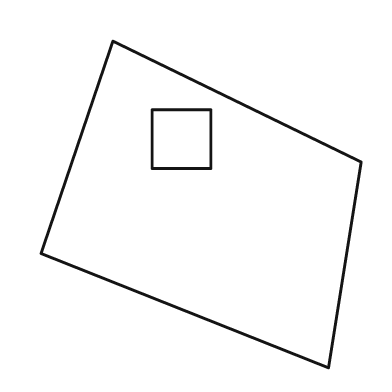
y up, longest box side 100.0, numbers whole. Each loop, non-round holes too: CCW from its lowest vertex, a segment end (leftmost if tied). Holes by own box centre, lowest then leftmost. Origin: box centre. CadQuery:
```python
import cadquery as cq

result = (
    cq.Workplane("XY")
    .moveTo(39.0, -50.0)
    .lineTo(49.0, 13.0)
    .lineTo(-27.0, 50.0)
    .lineTo(-49.0, -15.0)
    .close()
    .moveTo(-15.0, 11.0)
    .lineTo(3.0, 11.0)
    .lineTo(3.0, 29.0)
    .lineTo(-15.0, 29.0)
    .close()
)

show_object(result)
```